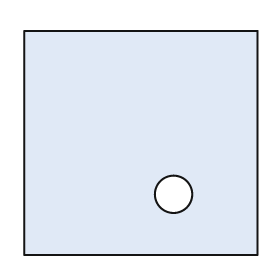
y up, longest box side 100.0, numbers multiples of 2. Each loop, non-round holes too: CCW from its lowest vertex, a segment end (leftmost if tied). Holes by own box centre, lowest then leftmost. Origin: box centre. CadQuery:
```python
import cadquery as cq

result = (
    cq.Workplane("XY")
    .moveTo(-50.0, -48.0)
    .lineTo(50.0, -48.0)
    .lineTo(50.0, 48.0)
    .lineTo(-50.0, 48.0)
    .close()
    .moveTo(14.0, -22.0)
    .circle(8.0)
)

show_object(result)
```